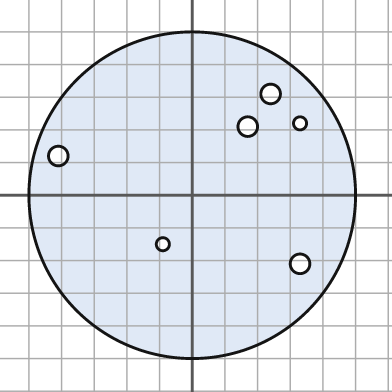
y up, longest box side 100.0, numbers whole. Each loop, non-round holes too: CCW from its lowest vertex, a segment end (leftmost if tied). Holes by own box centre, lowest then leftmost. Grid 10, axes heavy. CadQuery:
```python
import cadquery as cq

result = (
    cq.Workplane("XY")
    .moveTo(0.0, 0.0)
    .circle(50.0)
    .moveTo(33.0, -21.0)
    .circle(3.0)
    .moveTo(-9.0, -15.0)
    .circle(2.0)
    .moveTo(-41.0, 12.0)
    .circle(3.0)
    .moveTo(17.0, 21.0)
    .circle(3.0)
    .moveTo(33.0, 22.0)
    .circle(2.0)
    .moveTo(24.0, 31.0)
    .circle(3.0)
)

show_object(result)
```